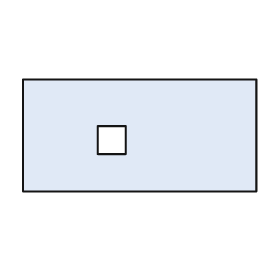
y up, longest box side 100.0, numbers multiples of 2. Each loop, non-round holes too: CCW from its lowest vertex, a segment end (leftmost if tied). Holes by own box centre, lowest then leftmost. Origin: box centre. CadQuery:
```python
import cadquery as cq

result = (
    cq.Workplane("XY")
    .moveTo(-50.0, -24.0)
    .lineTo(50.0, -24.0)
    .lineTo(50.0, 24.0)
    .lineTo(-50.0, 24.0)
    .close()
    .moveTo(-18.0, -8.0)
    .lineTo(-6.0, -8.0)
    .lineTo(-6.0, 4.0)
    .lineTo(-18.0, 4.0)
    .close()
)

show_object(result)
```